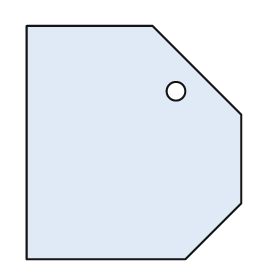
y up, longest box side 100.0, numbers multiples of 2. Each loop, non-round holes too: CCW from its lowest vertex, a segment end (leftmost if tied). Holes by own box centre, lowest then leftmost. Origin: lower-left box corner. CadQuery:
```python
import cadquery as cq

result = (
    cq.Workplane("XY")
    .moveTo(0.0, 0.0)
    .lineTo(68.0, 0.0)
    .lineTo(92.0, 24.0)
    .lineTo(92.0, 62.0)
    .lineTo(54.0, 100.0)
    .lineTo(0.0, 100.0)
    .close()
    .moveTo(64.0, 72.0)
    .circle(4.0)
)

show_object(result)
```